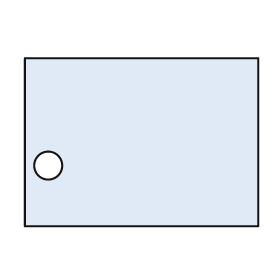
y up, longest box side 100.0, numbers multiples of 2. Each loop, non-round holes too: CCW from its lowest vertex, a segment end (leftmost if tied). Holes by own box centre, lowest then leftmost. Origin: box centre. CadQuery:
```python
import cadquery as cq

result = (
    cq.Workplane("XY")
    .moveTo(-50.0, -36.0)
    .lineTo(50.0, -36.0)
    .lineTo(50.0, 36.0)
    .lineTo(-50.0, 36.0)
    .close()
    .moveTo(-40.0, -10.0)
    .circle(6.0)
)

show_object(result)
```